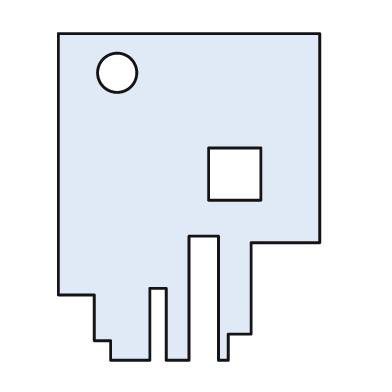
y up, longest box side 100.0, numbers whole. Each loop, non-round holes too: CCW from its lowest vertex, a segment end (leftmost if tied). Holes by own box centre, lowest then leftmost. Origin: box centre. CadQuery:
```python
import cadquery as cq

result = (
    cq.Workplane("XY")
    .moveTo(-24.0, -50.0)
    .lineTo(-12.0, -50.0)
    .lineTo(-12.0, -28.0)
    .lineTo(-7.0, -28.0)
    .lineTo(-7.0, -50.0)
    .lineTo(0.0, -50.0)
    .lineTo(0.0, -12.0)
    .lineTo(9.0, -12.0)
    .lineTo(9.0, -50.0)
    .lineTo(12.0, -50.0)
    .lineTo(12.0, -42.0)
    .lineTo(19.0, -42.0)
    .lineTo(19.0, -14.0)
    .lineTo(40.0, -14.0)
    .lineTo(40.0, 50.0)
    .lineTo(-40.0, 50.0)
    .lineTo(-40.0, -30.0)
    .lineTo(-29.0, -30.0)
    .lineTo(-29.0, -44.0)
    .lineTo(-24.0, -44.0)
    .close()
    .moveTo(6.0, -1.0)
    .lineTo(22.0, -1.0)
    .lineTo(22.0, 15.0)
    .lineTo(6.0, 15.0)
    .close()
    .moveTo(-22.0, 38.0)
    .circle(6.0)
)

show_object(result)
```